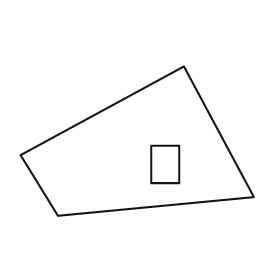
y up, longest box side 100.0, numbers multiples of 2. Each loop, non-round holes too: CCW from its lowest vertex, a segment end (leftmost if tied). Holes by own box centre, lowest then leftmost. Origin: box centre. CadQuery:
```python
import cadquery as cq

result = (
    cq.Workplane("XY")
    .moveTo(-34.0, -32.0)
    .lineTo(50.0, -24.0)
    .lineTo(20.0, 32.0)
    .lineTo(-50.0, -6.0)
    .close()
    .moveTo(6.0, -18.0)
    .lineTo(18.0, -18.0)
    .lineTo(18.0, -2.0)
    .lineTo(6.0, -2.0)
    .close()
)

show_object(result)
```